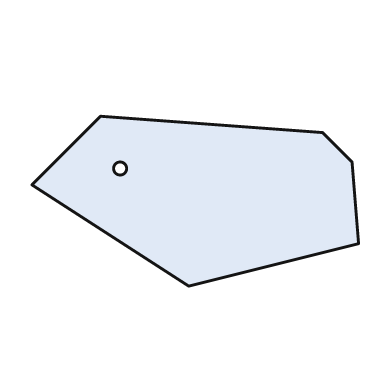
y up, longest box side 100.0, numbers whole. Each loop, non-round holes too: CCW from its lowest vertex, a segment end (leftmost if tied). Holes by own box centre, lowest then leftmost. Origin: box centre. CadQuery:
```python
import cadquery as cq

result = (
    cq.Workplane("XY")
    .moveTo(-2.0, -26.0)
    .lineTo(50.0, -13.0)
    .lineTo(48.0, 12.0)
    .lineTo(39.0, 21.0)
    .lineTo(-29.0, 26.0)
    .lineTo(-50.0, 5.0)
    .close()
    .moveTo(-23.0, 10.0)
    .circle(2.0)
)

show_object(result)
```